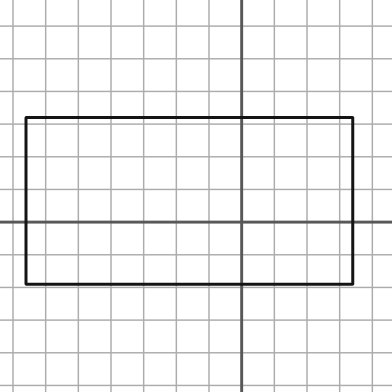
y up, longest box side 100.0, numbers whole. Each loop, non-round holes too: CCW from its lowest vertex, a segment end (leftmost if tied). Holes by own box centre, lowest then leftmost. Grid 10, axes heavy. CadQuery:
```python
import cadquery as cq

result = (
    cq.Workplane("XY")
    .moveTo(-66.0, -19.0)
    .lineTo(34.0, -19.0)
    .lineTo(34.0, 32.0)
    .lineTo(-66.0, 32.0)
    .close()
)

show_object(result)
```